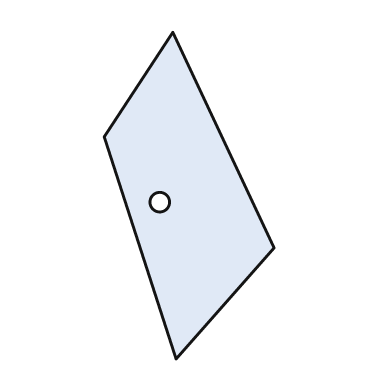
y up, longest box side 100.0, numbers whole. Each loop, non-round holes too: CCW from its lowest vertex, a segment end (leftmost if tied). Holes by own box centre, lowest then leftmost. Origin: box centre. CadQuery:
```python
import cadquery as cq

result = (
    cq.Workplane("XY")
    .moveTo(-4.0, -50.0)
    .lineTo(26.0, -16.0)
    .lineTo(-5.0, 50.0)
    .lineTo(-26.0, 18.0)
    .close()
    .moveTo(-9.0, -2.0)
    .circle(3.0)
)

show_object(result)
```